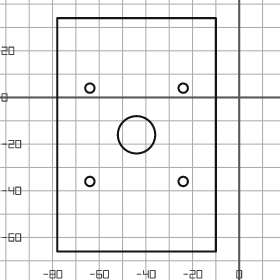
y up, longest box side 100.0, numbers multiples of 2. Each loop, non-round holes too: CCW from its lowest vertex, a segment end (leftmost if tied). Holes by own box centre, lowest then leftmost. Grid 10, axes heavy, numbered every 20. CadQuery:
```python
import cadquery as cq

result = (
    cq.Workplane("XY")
    .moveTo(-78.0, -66.0)
    .lineTo(-10.0, -66.0)
    .lineTo(-10.0, 34.0)
    .lineTo(-78.0, 34.0)
    .close()
    .moveTo(-64.0, -36.0)
    .circle(2.0)
    .moveTo(-24.0, -36.0)
    .circle(2.0)
    .moveTo(-44.0, -16.0)
    .circle(8.0)
    .moveTo(-64.0, 4.0)
    .circle(2.0)
    .moveTo(-24.0, 4.0)
    .circle(2.0)
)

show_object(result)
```